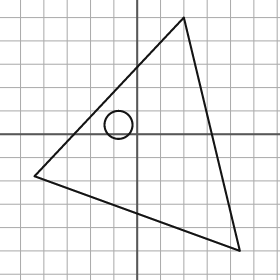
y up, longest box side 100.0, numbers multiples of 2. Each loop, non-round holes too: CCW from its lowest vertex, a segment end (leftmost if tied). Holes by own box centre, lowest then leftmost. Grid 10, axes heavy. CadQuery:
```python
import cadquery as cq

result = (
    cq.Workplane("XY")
    .moveTo(44.0, -50.0)
    .lineTo(20.0, 50.0)
    .lineTo(-44.0, -18.0)
    .close()
    .moveTo(-8.0, 4.0)
    .circle(6.0)
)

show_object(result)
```